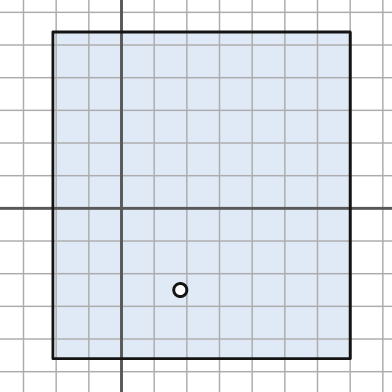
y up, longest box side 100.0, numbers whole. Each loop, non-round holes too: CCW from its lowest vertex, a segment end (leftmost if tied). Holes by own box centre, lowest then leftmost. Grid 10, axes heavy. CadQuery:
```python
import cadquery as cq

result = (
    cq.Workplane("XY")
    .moveTo(-21.0, -46.0)
    .lineTo(70.0, -46.0)
    .lineTo(70.0, 54.0)
    .lineTo(-21.0, 54.0)
    .close()
    .moveTo(18.0, -25.0)
    .circle(2.0)
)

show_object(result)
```